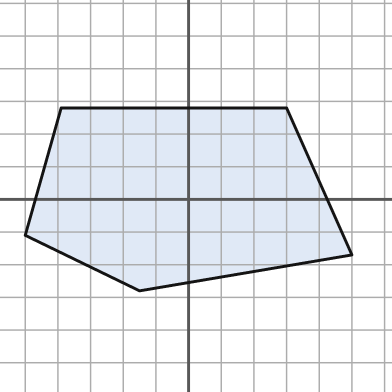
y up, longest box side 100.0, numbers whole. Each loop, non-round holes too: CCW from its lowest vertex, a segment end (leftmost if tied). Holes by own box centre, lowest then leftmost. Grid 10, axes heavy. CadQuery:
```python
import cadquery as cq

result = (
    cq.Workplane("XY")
    .moveTo(-15.0, -28.0)
    .lineTo(50.0, -17.0)
    .lineTo(30.0, 28.0)
    .lineTo(-39.0, 28.0)
    .lineTo(-50.0, -11.0)
    .close()
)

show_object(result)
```